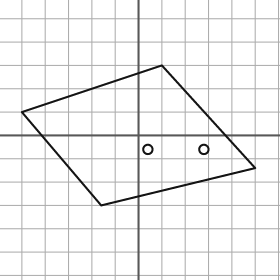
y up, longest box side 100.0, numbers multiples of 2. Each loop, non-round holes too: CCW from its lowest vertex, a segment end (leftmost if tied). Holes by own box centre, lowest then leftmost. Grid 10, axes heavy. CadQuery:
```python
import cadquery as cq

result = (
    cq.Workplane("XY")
    .moveTo(-16.0, -30.0)
    .lineTo(50.0, -14.0)
    .lineTo(10.0, 30.0)
    .lineTo(-50.0, 10.0)
    .close()
    .moveTo(4.0, -6.0)
    .circle(2.0)
    .moveTo(28.0, -6.0)
    .circle(2.0)
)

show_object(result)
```